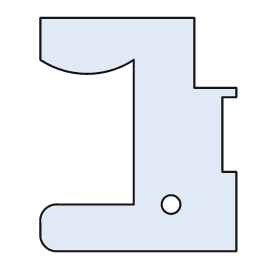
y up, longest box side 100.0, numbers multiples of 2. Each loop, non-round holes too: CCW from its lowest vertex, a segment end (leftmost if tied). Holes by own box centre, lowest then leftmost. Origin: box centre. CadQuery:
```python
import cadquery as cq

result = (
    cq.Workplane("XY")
    .moveTo(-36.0, -50.0)
    .lineTo(42.0, -50.0)
    .lineTo(42.0, -16.0)
    .lineTo(36.0, -16.0)
    .lineTo(36.0, 16.0)
    .lineTo(42.0, 16.0)
    .lineTo(42.0, 20.0)
    .lineTo(24.0, 20.0)
    .lineTo(24.0, 50.0)
    .lineTo(-42.0, 50.0)
    .lineTo(-42.0, 32.0)
    .threePointArc((-22.0, 26.0), (-2.0, 32.0))
    .lineTo(-2.0, -30.0)
    .lineTo(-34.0, -30.0)
    .threePointArc((-40.0, -32.0), (-42.0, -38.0))
    .lineTo(-42.0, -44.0)
    .threePointArc((-40.0, -48.0), (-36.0, -50.0))
    .close()
    .moveTo(14.0, -30.0)
    .circle(4.0)
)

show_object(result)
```